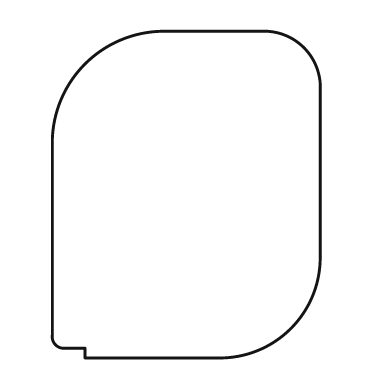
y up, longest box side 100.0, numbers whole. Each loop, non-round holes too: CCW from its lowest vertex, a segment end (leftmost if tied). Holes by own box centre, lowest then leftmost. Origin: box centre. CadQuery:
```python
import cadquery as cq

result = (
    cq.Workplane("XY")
    .moveTo(-31.0, -50.0)
    .lineTo(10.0, -50.0)
    .threePointArc((32.0, -41.0), (41.0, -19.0))
    .lineTo(41.0, 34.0)
    .threePointArc((36.0, 45.0), (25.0, 50.0))
    .lineTo(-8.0, 50.0)
    .threePointArc((-31.0, 40.0), (-41.0, 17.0))
    .lineTo(-41.0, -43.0)
    .threePointArc((-40.0, -46.0), (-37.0, -47.0))
    .lineTo(-31.0, -47.0)
    .close()
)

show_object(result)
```